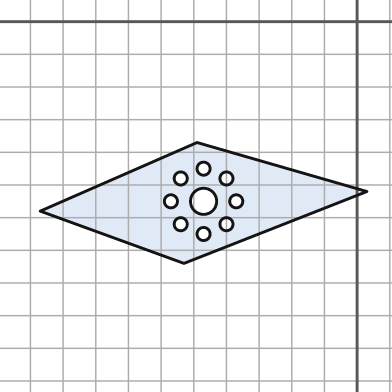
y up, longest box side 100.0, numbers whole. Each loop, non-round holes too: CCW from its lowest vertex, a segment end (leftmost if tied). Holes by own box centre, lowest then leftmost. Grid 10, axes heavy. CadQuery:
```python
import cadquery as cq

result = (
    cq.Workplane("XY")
    .moveTo(-53.0, -74.0)
    .lineTo(3.0, -52.0)
    .lineTo(-49.0, -37.0)
    .lineTo(-97.0, -58.0)
    .close()
    .moveTo(-47.0, -65.0)
    .circle(2.0)
    .moveTo(-54.0, -62.0)
    .circle(2.0)
    .moveTo(-40.0, -62.0)
    .circle(2.0)
    .moveTo(-57.0, -55.0)
    .circle(2.0)
    .moveTo(-47.0, -55.0)
    .circle(4.0)
    .moveTo(-37.0, -55.0)
    .circle(2.0)
    .moveTo(-54.0, -48.0)
    .circle(2.0)
    .moveTo(-40.0, -48.0)
    .circle(2.0)
    .moveTo(-47.0, -45.0)
    .circle(2.0)
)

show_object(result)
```